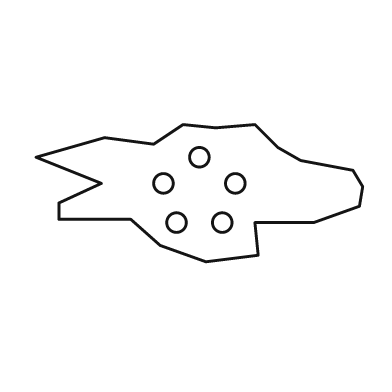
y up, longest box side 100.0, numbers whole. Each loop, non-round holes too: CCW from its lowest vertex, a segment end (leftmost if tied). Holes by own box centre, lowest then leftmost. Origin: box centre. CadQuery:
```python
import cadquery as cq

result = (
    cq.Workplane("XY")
    .moveTo(2.0, -21.0)
    .lineTo(18.0, -19.0)
    .lineTo(17.0, -9.0)
    .lineTo(35.0, -9.0)
    .lineTo(49.0, -4.0)
    .lineTo(50.0, 2.0)
    .lineTo(47.0, 7.0)
    .lineTo(31.0, 10.0)
    .lineTo(24.0, 14.0)
    .lineTo(17.0, 21.0)
    .lineTo(5.0, 20.0)
    .lineTo(-5.0, 21.0)
    .lineTo(-14.0, 15.0)
    .lineTo(-29.0, 17.0)
    .lineTo(-50.0, 11.0)
    .lineTo(-30.0, 3.0)
    .lineTo(-43.0, -3.0)
    .lineTo(-43.0, -8.0)
    .lineTo(-21.0, -8.0)
    .lineTo(-12.0, -16.0)
    .close()
    .moveTo(-7.0, -9.0)
    .circle(3.0)
    .moveTo(7.0, -9.0)
    .circle(3.0)
    .moveTo(-11.0, 3.0)
    .circle(3.0)
    .moveTo(11.0, 3.0)
    .circle(3.0)
    .moveTo(0.0, 11.0)
    .circle(3.0)
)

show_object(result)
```